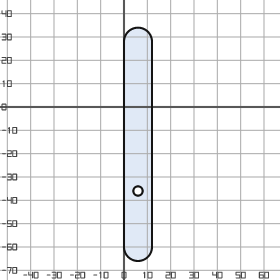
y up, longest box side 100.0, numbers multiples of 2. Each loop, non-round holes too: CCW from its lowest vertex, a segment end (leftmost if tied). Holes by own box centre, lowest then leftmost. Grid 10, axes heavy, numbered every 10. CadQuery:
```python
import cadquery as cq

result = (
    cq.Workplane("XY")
    .moveTo(0.0, -60.0)
    .threePointArc((6.0, -66.0), (12.0, -60.0))
    .lineTo(12.0, 28.0)
    .threePointArc((6.0, 34.0), (0.0, 28.0))
    .close()
    .moveTo(6.0, -36.0)
    .circle(2.0)
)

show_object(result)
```